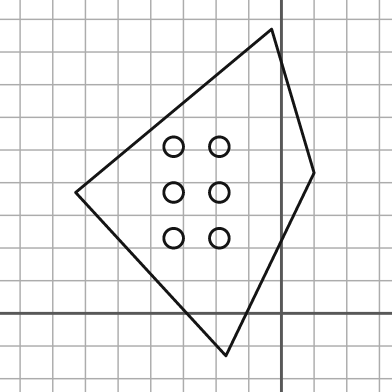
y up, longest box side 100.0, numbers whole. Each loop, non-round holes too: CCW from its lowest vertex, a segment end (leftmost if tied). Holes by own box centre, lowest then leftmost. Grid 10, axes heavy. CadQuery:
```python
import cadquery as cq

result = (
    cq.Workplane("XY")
    .moveTo(-17.0, -13.0)
    .lineTo(10.0, 43.0)
    .lineTo(-3.0, 87.0)
    .lineTo(-63.0, 37.0)
    .close()
    .moveTo(-33.0, 23.0)
    .circle(3.0)
    .moveTo(-19.0, 23.0)
    .circle(3.0)
    .moveTo(-33.0, 37.0)
    .circle(3.0)
    .moveTo(-19.0, 37.0)
    .circle(3.0)
    .moveTo(-33.0, 51.0)
    .circle(3.0)
    .moveTo(-19.0, 51.0)
    .circle(3.0)
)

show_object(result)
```